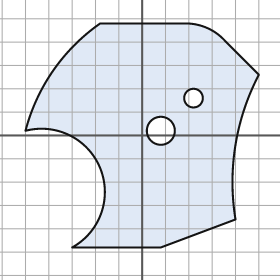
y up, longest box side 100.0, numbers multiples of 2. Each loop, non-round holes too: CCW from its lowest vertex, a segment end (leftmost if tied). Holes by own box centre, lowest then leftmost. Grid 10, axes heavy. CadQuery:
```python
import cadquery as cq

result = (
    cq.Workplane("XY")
    .moveTo(-30.0, -48.0)
    .lineTo(8.0, -48.0)
    .lineTo(40.0, -36.0)
    .threePointArc((40.0, -4.0), (50.0, 26.0))
    .lineTo(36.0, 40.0)
    .threePointArc((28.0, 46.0), (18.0, 48.0))
    .lineTo(-18.0, 48.0)
    .threePointArc((-38.0, 28.0), (-50.0, 2.0))
    .threePointArc((-18.0, -14.0), (-30.0, -48.0))
    .close()
    .moveTo(8.0, 2.0)
    .circle(6.0)
    .moveTo(22.0, 16.0)
    .circle(4.0)
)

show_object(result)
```